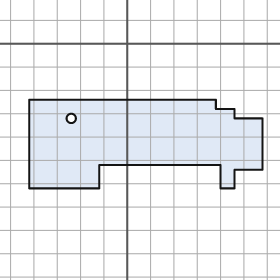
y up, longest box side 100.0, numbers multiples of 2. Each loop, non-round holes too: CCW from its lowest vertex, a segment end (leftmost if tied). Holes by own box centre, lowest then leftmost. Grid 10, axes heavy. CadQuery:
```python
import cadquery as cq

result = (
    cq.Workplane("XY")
    .moveTo(-42.0, -62.0)
    .lineTo(-12.0, -62.0)
    .lineTo(-12.0, -52.0)
    .lineTo(40.0, -52.0)
    .lineTo(40.0, -62.0)
    .lineTo(46.0, -62.0)
    .lineTo(46.0, -54.0)
    .lineTo(58.0, -54.0)
    .lineTo(58.0, -32.0)
    .lineTo(46.0, -32.0)
    .lineTo(46.0, -28.0)
    .lineTo(38.0, -28.0)
    .lineTo(38.0, -24.0)
    .lineTo(-42.0, -24.0)
    .close()
    .moveTo(-24.0, -32.0)
    .circle(2.0)
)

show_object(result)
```